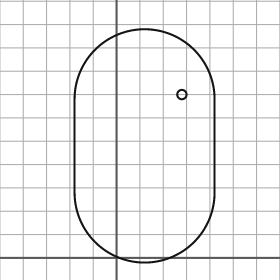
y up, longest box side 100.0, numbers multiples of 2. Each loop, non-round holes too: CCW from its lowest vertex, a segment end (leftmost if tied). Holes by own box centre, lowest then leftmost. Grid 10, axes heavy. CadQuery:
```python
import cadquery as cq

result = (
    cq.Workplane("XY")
    .moveTo(-18.0, 28.0)
    .threePointArc((12.0, -2.0), (42.0, 28.0))
    .lineTo(42.0, 68.0)
    .threePointArc((12.0, 98.0), (-18.0, 68.0))
    .close()
    .moveTo(28.0, 70.0)
    .circle(2.0)
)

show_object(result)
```